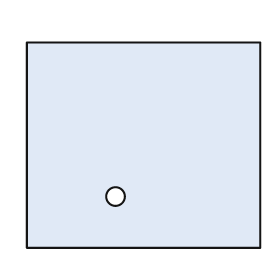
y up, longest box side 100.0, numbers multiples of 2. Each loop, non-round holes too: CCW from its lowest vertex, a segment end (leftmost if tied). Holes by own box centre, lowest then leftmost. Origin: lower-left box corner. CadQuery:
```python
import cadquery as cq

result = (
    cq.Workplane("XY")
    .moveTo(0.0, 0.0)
    .lineTo(100.0, 0.0)
    .lineTo(100.0, 88.0)
    .lineTo(0.0, 88.0)
    .close()
    .moveTo(38.0, 22.0)
    .circle(4.0)
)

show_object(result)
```